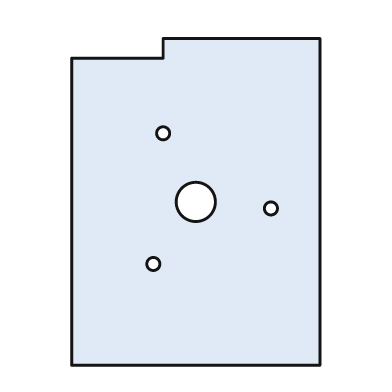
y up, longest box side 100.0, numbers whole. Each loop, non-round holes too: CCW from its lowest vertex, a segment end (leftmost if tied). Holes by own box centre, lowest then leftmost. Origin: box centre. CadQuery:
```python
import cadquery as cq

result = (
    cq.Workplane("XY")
    .moveTo(-38.0, -50.0)
    .lineTo(38.0, -50.0)
    .lineTo(38.0, 50.0)
    .lineTo(-10.0, 50.0)
    .lineTo(-10.0, 44.0)
    .lineTo(-38.0, 44.0)
    .close()
    .moveTo(-13.0, -19.0)
    .circle(2.0)
    .moveTo(23.0, -2.0)
    .circle(2.0)
    .moveTo(0.0, 0.0)
    .circle(6.0)
    .moveTo(-10.0, 21.0)
    .circle(2.0)
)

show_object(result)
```